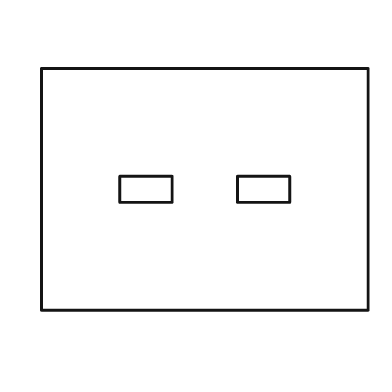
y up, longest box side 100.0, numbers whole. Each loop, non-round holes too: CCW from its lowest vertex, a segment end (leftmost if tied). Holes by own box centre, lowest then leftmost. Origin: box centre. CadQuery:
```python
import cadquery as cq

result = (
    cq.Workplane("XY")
    .moveTo(-50.0, -37.0)
    .lineTo(50.0, -37.0)
    .lineTo(50.0, 37.0)
    .lineTo(-50.0, 37.0)
    .close()
    .moveTo(-26.0, -4.0)
    .lineTo(-10.0, -4.0)
    .lineTo(-10.0, 4.0)
    .lineTo(-26.0, 4.0)
    .close()
    .moveTo(10.0, -4.0)
    .lineTo(26.0, -4.0)
    .lineTo(26.0, 4.0)
    .lineTo(10.0, 4.0)
    .close()
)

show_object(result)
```